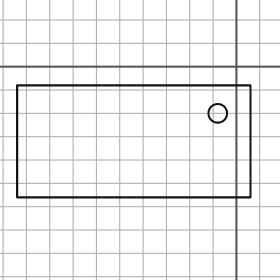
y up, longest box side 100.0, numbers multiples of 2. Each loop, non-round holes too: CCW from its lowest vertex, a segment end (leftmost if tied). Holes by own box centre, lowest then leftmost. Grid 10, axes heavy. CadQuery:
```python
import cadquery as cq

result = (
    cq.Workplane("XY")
    .moveTo(-94.0, -56.0)
    .lineTo(6.0, -56.0)
    .lineTo(6.0, -8.0)
    .lineTo(-94.0, -8.0)
    .close()
    .moveTo(-8.0, -20.0)
    .circle(4.0)
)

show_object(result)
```